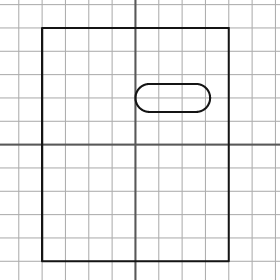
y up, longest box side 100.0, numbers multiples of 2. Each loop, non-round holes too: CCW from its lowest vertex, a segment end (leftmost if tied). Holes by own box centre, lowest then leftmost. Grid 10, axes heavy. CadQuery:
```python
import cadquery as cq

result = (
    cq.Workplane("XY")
    .moveTo(-40.0, -50.0)
    .lineTo(40.0, -50.0)
    .lineTo(40.0, 50.0)
    .lineTo(-40.0, 50.0)
    .close()
    .moveTo(6.0, 14.0)
    .lineTo(26.0, 14.0)
    .threePointArc((32.0, 20.0), (26.0, 26.0))
    .lineTo(6.0, 26.0)
    .threePointArc((0.0, 20.0), (6.0, 14.0))
    .close()
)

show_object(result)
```